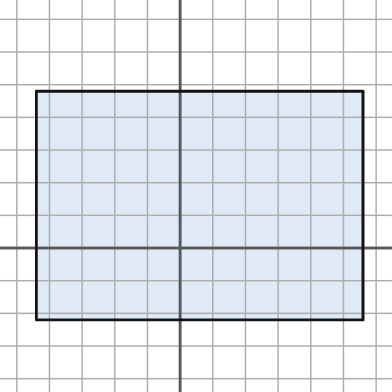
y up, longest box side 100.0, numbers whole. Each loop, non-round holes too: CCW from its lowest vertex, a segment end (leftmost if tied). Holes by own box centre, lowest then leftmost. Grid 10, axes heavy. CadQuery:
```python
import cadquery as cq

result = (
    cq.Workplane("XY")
    .moveTo(-44.0, -22.0)
    .lineTo(56.0, -22.0)
    .lineTo(56.0, 48.0)
    .lineTo(-44.0, 48.0)
    .close()
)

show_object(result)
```